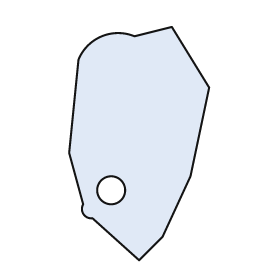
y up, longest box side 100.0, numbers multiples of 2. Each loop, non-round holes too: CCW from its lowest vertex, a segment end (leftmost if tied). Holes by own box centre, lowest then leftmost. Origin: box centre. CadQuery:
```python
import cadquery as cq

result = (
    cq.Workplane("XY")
    .moveTo(0.0, -50.0)
    .lineTo(10.0, -40.0)
    .lineTo(22.0, -14.0)
    .lineTo(30.0, 24.0)
    .lineTo(14.0, 50.0)
    .lineTo(-2.0, 46.0)
    .threePointArc((-16.0, 46.0), (-26.0, 36.0))
    .lineTo(-30.0, -4.0)
    .lineTo(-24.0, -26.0)
    .threePointArc((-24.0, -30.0), (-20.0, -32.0))
    .close()
    .moveTo(-12.0, -20.0)
    .circle(6.0)
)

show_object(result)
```